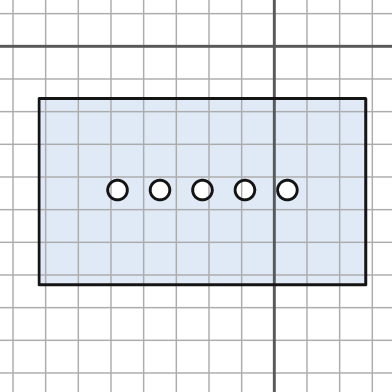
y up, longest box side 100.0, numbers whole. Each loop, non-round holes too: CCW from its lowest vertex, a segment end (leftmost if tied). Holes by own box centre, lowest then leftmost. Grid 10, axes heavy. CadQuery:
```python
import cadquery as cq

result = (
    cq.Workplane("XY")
    .moveTo(-72.0, -73.0)
    .lineTo(28.0, -73.0)
    .lineTo(28.0, -16.0)
    .lineTo(-72.0, -16.0)
    .close()
    .moveTo(-48.0, -44.0)
    .circle(3.0)
    .moveTo(-35.0, -44.0)
    .circle(3.0)
    .moveTo(-22.0, -44.0)
    .circle(3.0)
    .moveTo(-9.0, -44.0)
    .circle(3.0)
    .moveTo(4.0, -44.0)
    .circle(3.0)
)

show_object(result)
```